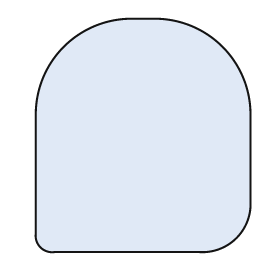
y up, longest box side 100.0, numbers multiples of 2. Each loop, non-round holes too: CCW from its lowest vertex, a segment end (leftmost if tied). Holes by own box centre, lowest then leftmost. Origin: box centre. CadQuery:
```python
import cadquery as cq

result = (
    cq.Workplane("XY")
    .moveTo(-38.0, -50.0)
    .lineTo(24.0, -50.0)
    .threePointArc((40.0, -44.0), (46.0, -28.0))
    .lineTo(46.0, 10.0)
    .threePointArc((34.0, 38.0), (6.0, 50.0))
    .lineTo(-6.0, 50.0)
    .threePointArc((-34.0, 38.0), (-46.0, 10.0))
    .lineTo(-46.0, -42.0)
    .threePointArc((-44.0, -48.0), (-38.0, -50.0))
    .close()
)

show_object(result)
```